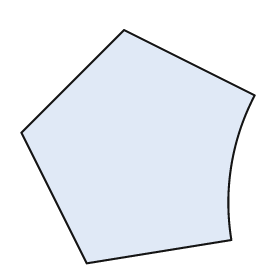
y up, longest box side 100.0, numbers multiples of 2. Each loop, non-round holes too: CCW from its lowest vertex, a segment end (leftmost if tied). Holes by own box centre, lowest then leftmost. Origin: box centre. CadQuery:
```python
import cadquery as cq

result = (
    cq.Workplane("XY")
    .moveTo(-22.0, -50.0)
    .lineTo(40.0, -40.0)
    .threePointArc((40.0, -8.0), (50.0, 22.0))
    .lineTo(-6.0, 50.0)
    .lineTo(-50.0, 6.0)
    .close()
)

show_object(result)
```